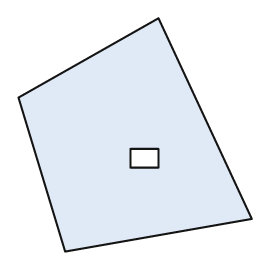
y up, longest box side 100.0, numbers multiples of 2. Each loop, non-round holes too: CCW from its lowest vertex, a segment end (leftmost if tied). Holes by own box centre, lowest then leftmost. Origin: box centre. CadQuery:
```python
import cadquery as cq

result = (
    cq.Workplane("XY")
    .moveTo(-30.0, -50.0)
    .lineTo(50.0, -36.0)
    .lineTo(10.0, 50.0)
    .lineTo(-50.0, 16.0)
    .close()
    .moveTo(-2.0, -14.0)
    .lineTo(10.0, -14.0)
    .lineTo(10.0, -6.0)
    .lineTo(-2.0, -6.0)
    .close()
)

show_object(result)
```